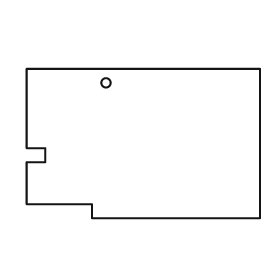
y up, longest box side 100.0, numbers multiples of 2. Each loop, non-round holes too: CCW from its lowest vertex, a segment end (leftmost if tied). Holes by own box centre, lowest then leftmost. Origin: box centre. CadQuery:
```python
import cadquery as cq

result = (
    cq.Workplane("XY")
    .moveTo(-22.0, -32.0)
    .lineTo(50.0, -32.0)
    .lineTo(50.0, 32.0)
    .lineTo(-50.0, 32.0)
    .lineTo(-50.0, -2.0)
    .lineTo(-42.0, -2.0)
    .lineTo(-42.0, -8.0)
    .lineTo(-50.0, -8.0)
    .lineTo(-50.0, -26.0)
    .lineTo(-22.0, -26.0)
    .close()
    .moveTo(-16.0, 26.0)
    .circle(2.0)
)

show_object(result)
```